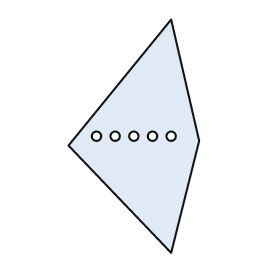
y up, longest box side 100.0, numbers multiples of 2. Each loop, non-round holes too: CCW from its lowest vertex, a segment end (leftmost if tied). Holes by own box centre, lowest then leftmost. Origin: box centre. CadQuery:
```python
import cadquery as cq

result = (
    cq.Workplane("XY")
    .moveTo(16.0, -50.0)
    .lineTo(28.0, -2.0)
    .lineTo(16.0, 50.0)
    .lineTo(-28.0, -4.0)
    .close()
    .moveTo(-16.0, 0.0)
    .circle(2.0)
    .moveTo(-8.0, 0.0)
    .circle(2.0)
    .moveTo(0.0, 0.0)
    .circle(2.0)
    .moveTo(8.0, 0.0)
    .circle(2.0)
    .moveTo(16.0, 0.0)
    .circle(2.0)
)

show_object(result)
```